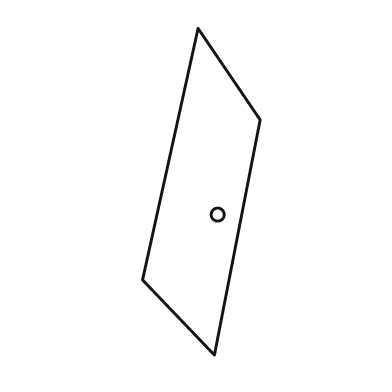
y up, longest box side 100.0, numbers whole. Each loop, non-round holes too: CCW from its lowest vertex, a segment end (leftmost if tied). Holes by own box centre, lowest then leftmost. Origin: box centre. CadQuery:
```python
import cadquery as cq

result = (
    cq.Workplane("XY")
    .moveTo(4.0, -50.0)
    .lineTo(18.0, 22.0)
    .lineTo(-1.0, 50.0)
    .lineTo(-18.0, -27.0)
    .close()
    .moveTo(5.0, -7.0)
    .circle(2.0)
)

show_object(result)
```